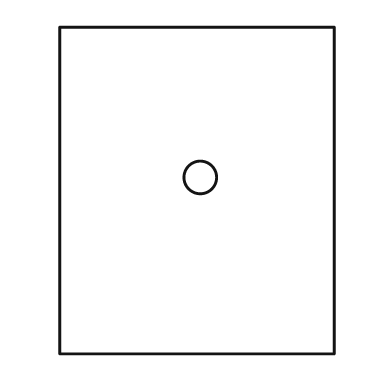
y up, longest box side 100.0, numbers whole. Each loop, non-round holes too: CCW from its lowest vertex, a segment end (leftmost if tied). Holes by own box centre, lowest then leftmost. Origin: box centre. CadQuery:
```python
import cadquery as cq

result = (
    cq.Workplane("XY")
    .moveTo(-42.0, -50.0)
    .lineTo(42.0, -50.0)
    .lineTo(42.0, 50.0)
    .lineTo(-42.0, 50.0)
    .close()
    .moveTo(1.0, 4.0)
    .circle(5.0)
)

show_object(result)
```